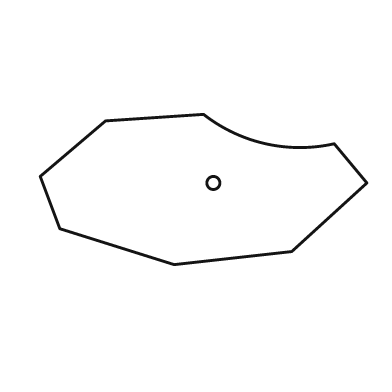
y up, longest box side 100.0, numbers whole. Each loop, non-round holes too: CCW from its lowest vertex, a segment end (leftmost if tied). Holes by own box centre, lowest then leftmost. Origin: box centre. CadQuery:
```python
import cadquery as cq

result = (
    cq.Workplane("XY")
    .moveTo(-9.0, -23.0)
    .lineTo(27.0, -19.0)
    .lineTo(50.0, 2.0)
    .lineTo(40.0, 14.0)
    .threePointArc((19.0, 14.0), (0.0, 23.0))
    .lineTo(-30.0, 21.0)
    .lineTo(-50.0, 4.0)
    .lineTo(-44.0, -12.0)
    .close()
    .moveTo(3.0, 2.0)
    .circle(2.0)
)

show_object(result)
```